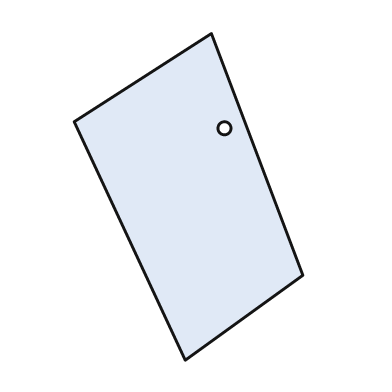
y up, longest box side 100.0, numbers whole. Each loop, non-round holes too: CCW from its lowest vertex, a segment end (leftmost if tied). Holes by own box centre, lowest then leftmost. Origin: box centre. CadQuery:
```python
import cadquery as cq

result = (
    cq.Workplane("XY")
    .moveTo(-1.0, -50.0)
    .lineTo(35.0, -24.0)
    .lineTo(7.0, 50.0)
    .lineTo(-35.0, 23.0)
    .close()
    .moveTo(11.0, 21.0)
    .circle(2.0)
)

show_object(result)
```